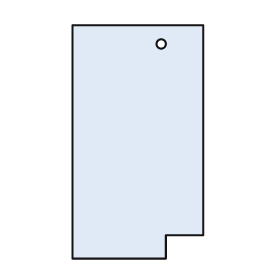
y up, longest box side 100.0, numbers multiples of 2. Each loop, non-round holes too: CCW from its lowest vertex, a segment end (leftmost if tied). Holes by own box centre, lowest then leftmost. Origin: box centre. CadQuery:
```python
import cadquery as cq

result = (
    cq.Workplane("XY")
    .moveTo(-28.0, -50.0)
    .lineTo(12.0, -50.0)
    .lineTo(12.0, -40.0)
    .lineTo(28.0, -40.0)
    .lineTo(28.0, 50.0)
    .lineTo(-28.0, 50.0)
    .close()
    .moveTo(10.0, 42.0)
    .circle(2.0)
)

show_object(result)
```